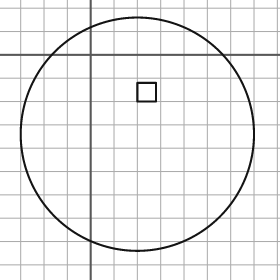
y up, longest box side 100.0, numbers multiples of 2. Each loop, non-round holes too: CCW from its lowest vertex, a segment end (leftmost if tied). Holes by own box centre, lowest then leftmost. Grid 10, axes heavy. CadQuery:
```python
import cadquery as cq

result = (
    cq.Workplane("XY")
    .moveTo(20.0, -34.0)
    .circle(50.0)
    .moveTo(20.0, -20.0)
    .lineTo(28.0, -20.0)
    .lineTo(28.0, -12.0)
    .lineTo(20.0, -12.0)
    .close()
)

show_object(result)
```